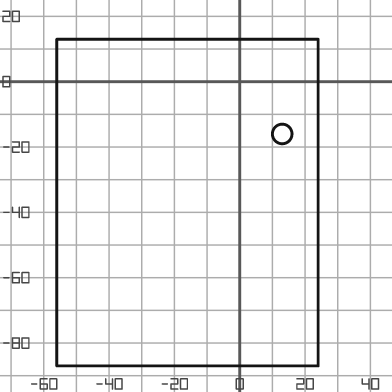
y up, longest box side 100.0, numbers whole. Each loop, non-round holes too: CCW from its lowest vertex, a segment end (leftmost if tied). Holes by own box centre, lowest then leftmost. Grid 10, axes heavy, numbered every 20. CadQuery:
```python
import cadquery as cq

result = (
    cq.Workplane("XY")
    .moveTo(-56.0, -87.0)
    .lineTo(24.0, -87.0)
    .lineTo(24.0, 13.0)
    .lineTo(-56.0, 13.0)
    .close()
    .moveTo(13.0, -16.0)
    .circle(3.0)
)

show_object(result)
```